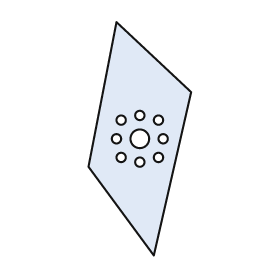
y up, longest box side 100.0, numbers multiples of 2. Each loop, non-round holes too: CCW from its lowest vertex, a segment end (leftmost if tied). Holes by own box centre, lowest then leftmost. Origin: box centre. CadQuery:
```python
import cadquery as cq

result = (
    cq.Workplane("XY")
    .moveTo(6.0, -50.0)
    .lineTo(22.0, 20.0)
    .lineTo(-10.0, 50.0)
    .lineTo(-22.0, -12.0)
    .close()
    .moveTo(0.0, -10.0)
    .circle(2.0)
    .moveTo(-8.0, -8.0)
    .circle(2.0)
    .moveTo(8.0, -8.0)
    .circle(2.0)
    .moveTo(-10.0, 0.0)
    .circle(2.0)
    .moveTo(0.0, 0.0)
    .circle(4.0)
    .moveTo(10.0, 0.0)
    .circle(2.0)
    .moveTo(-8.0, 8.0)
    .circle(2.0)
    .moveTo(8.0, 8.0)
    .circle(2.0)
    .moveTo(0.0, 10.0)
    .circle(2.0)
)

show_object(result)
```